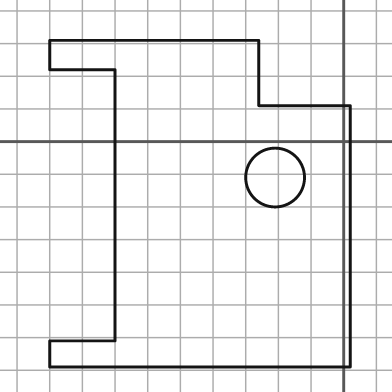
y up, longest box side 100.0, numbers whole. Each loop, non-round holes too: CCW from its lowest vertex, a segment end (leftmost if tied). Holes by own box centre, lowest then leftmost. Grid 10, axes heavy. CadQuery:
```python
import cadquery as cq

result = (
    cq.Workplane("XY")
    .moveTo(-90.0, -69.0)
    .lineTo(2.0, -69.0)
    .lineTo(2.0, 11.0)
    .lineTo(-26.0, 11.0)
    .lineTo(-26.0, 31.0)
    .lineTo(-90.0, 31.0)
    .lineTo(-90.0, 22.0)
    .lineTo(-70.0, 22.0)
    .lineTo(-70.0, -61.0)
    .lineTo(-90.0, -61.0)
    .close()
    .moveTo(-21.0, -11.0)
    .circle(9.0)
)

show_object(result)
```